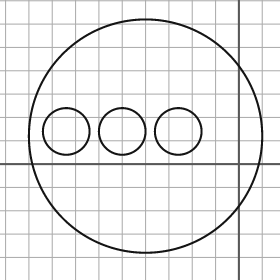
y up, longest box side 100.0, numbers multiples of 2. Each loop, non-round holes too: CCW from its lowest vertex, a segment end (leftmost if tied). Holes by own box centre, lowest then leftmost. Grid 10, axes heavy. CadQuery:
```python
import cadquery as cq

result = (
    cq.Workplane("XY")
    .moveTo(-40.0, 12.0)
    .circle(50.0)
    .moveTo(-74.0, 14.0)
    .circle(10.0)
    .moveTo(-50.0, 14.0)
    .circle(10.0)
    .moveTo(-26.0, 14.0)
    .circle(10.0)
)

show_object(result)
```